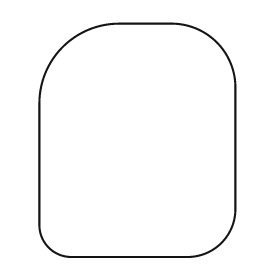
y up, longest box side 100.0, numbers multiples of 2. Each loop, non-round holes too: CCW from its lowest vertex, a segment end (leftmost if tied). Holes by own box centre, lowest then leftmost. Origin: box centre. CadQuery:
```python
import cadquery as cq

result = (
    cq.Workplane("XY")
    .moveTo(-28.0, -50.0)
    .lineTo(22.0, -50.0)
    .threePointArc((36.0, -44.0), (42.0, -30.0))
    .lineTo(42.0, 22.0)
    .threePointArc((34.0, 42.0), (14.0, 50.0))
    .lineTo(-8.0, 50.0)
    .threePointArc((-32.0, 40.0), (-42.0, 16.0))
    .lineTo(-42.0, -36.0)
    .threePointArc((-38.0, -46.0), (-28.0, -50.0))
    .close()
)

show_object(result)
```